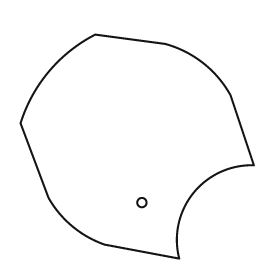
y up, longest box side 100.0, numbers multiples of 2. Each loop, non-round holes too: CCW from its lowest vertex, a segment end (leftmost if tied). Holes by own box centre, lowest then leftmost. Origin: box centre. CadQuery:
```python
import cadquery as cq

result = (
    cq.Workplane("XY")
    .moveTo(18.0, -48.0)
    .threePointArc((24.0, -20.0), (50.0, -8.0))
    .lineTo(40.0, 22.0)
    .threePointArc((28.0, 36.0), (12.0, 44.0))
    .lineTo(-18.0, 48.0)
    .threePointArc((-38.0, 32.0), (-50.0, 10.0))
    .lineTo(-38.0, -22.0)
    .threePointArc((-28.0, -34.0), (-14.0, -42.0))
    .close()
    .moveTo(2.0, -24.0)
    .circle(2.0)
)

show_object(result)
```